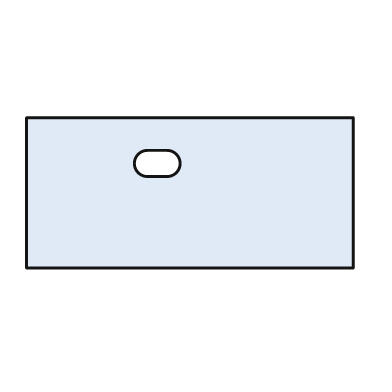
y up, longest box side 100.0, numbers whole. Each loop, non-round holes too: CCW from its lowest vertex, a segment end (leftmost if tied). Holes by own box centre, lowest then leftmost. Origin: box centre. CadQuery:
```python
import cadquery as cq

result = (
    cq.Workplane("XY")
    .moveTo(-50.0, -23.0)
    .lineTo(50.0, -23.0)
    .lineTo(50.0, 23.0)
    .lineTo(-50.0, 23.0)
    .close()
    .moveTo(-13.0, 5.0)
    .lineTo(-7.0, 5.0)
    .threePointArc((-3.0, 9.0), (-7.0, 13.0))
    .lineTo(-13.0, 13.0)
    .threePointArc((-17.0, 9.0), (-13.0, 5.0))
    .close()
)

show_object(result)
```